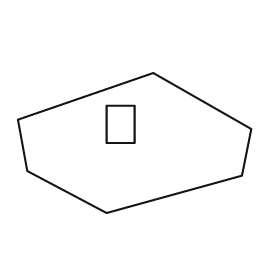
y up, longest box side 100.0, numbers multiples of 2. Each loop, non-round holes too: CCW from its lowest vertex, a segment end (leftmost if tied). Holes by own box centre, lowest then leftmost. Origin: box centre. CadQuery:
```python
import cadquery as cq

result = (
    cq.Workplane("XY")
    .moveTo(-12.0, -30.0)
    .lineTo(46.0, -14.0)
    .lineTo(50.0, 6.0)
    .lineTo(8.0, 30.0)
    .lineTo(-50.0, 10.0)
    .lineTo(-46.0, -12.0)
    .close()
    .moveTo(-12.0, 0.0)
    .lineTo(0.0, 0.0)
    .lineTo(0.0, 16.0)
    .lineTo(-12.0, 16.0)
    .close()
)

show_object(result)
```